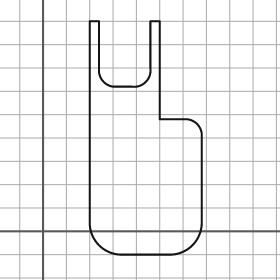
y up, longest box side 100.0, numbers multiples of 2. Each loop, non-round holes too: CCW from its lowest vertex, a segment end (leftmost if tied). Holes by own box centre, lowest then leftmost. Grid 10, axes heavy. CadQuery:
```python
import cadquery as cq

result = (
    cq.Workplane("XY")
    .moveTo(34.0, -10.0)
    .lineTo(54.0, -10.0)
    .threePointArc((64.0, -6.0), (68.0, 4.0))
    .lineTo(68.0, 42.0)
    .threePointArc((66.0, 46.0), (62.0, 48.0))
    .lineTo(50.0, 48.0)
    .lineTo(50.0, 90.0)
    .lineTo(46.0, 90.0)
    .lineTo(46.0, 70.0)
    .threePointArc((44.0, 64.0), (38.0, 62.0))
    .lineTo(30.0, 62.0)
    .threePointArc((26.0, 64.0), (24.0, 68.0))
    .lineTo(24.0, 90.0)
    .lineTo(20.0, 90.0)
    .lineTo(20.0, 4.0)
    .threePointArc((24.0, -6.0), (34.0, -10.0))
    .close()
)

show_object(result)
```